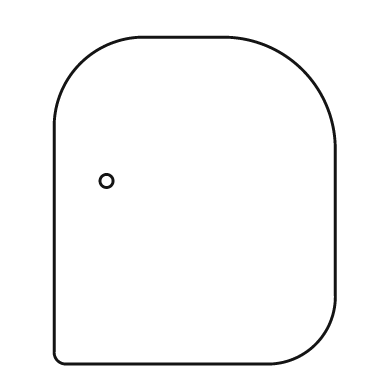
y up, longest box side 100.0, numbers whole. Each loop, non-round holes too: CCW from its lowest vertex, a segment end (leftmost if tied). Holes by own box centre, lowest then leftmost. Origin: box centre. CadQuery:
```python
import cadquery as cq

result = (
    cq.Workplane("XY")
    .moveTo(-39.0, -50.0)
    .lineTo(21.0, -50.0)
    .threePointArc((37.0, -44.0), (43.0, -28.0))
    .lineTo(43.0, 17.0)
    .threePointArc((33.0, 40.0), (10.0, 50.0))
    .lineTo(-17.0, 50.0)
    .threePointArc((-35.0, 42.0), (-43.0, 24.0))
    .lineTo(-43.0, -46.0)
    .threePointArc((-42.0, -49.0), (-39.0, -50.0))
    .close()
    .moveTo(-27.0, 6.0)
    .circle(2.0)
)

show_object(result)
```